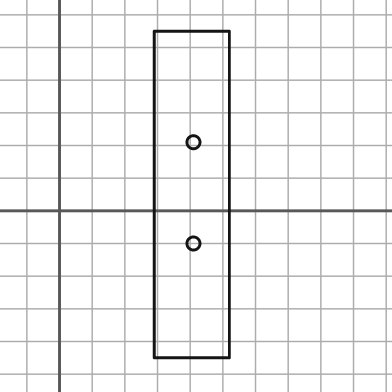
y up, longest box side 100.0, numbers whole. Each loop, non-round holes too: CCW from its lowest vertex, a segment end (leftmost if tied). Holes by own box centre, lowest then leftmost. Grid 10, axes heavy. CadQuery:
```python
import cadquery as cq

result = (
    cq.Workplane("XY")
    .moveTo(29.0, -45.0)
    .lineTo(52.0, -45.0)
    .lineTo(52.0, 55.0)
    .lineTo(29.0, 55.0)
    .close()
    .moveTo(41.0, -10.0)
    .circle(2.0)
    .moveTo(41.0, 21.0)
    .circle(2.0)
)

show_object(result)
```